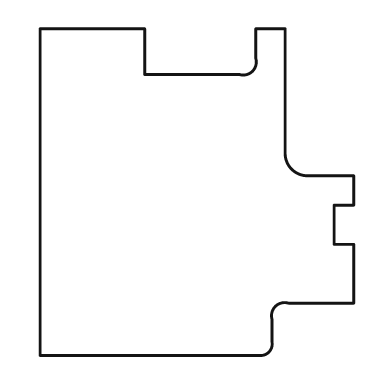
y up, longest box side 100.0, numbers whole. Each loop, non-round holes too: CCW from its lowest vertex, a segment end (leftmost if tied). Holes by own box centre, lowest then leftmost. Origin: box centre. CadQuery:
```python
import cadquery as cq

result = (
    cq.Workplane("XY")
    .moveTo(-48.0, -50.0)
    .lineTo(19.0, -50.0)
    .threePointArc((22.0, -49.0), (23.0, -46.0))
    .lineTo(23.0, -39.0)
    .threePointArc((24.0, -35.0), (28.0, -34.0))
    .lineTo(48.0, -34.0)
    .lineTo(48.0, -16.0)
    .lineTo(42.0, -16.0)
    .lineTo(42.0, -4.0)
    .lineTo(48.0, -4.0)
    .lineTo(48.0, 5.0)
    .lineTo(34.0, 5.0)
    .threePointArc((29.0, 7.0), (27.0, 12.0))
    .lineTo(27.0, 50.0)
    .lineTo(18.0, 50.0)
    .lineTo(18.0, 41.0)
    .threePointArc((17.0, 37.0), (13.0, 36.0))
    .lineTo(-16.0, 36.0)
    .lineTo(-16.0, 50.0)
    .lineTo(-48.0, 50.0)
    .close()
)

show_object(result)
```